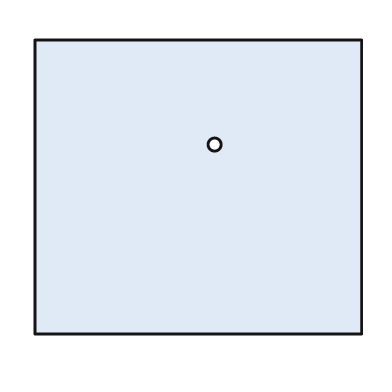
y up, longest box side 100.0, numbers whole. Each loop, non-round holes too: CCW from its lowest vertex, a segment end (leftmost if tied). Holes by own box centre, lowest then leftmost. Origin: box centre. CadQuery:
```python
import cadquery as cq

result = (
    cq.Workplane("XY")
    .moveTo(-50.0, -45.0)
    .lineTo(50.0, -45.0)
    .lineTo(50.0, 45.0)
    .lineTo(-50.0, 45.0)
    .close()
    .moveTo(5.0, 13.0)
    .circle(2.0)
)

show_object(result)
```